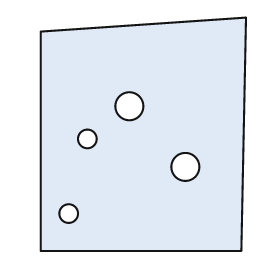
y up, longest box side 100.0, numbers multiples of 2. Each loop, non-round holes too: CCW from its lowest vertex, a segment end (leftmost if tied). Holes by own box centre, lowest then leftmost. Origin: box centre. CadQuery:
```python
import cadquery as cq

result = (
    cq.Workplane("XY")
    .moveTo(-44.0, -50.0)
    .lineTo(42.0, -50.0)
    .lineTo(44.0, 50.0)
    .lineTo(-44.0, 44.0)
    .close()
    .moveTo(-32.0, -34.0)
    .circle(4.0)
    .moveTo(18.0, -14.0)
    .circle(6.0)
    .moveTo(-24.0, -2.0)
    .circle(4.0)
    .moveTo(-6.0, 12.0)
    .circle(6.0)
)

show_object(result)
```